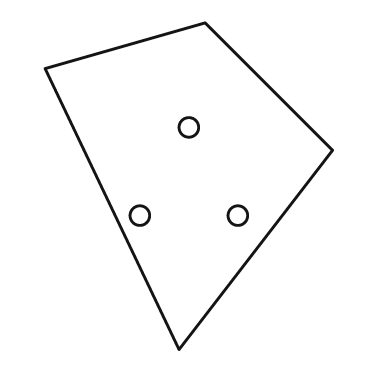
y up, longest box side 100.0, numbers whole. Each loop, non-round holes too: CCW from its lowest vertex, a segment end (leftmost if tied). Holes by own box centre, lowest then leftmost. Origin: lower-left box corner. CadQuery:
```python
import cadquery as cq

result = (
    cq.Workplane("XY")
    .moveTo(41.0, 0.0)
    .lineTo(88.0, 61.0)
    .lineTo(49.0, 100.0)
    .lineTo(0.0, 86.0)
    .close()
    .moveTo(29.0, 41.0)
    .circle(3.0)
    .moveTo(59.0, 41.0)
    .circle(3.0)
    .moveTo(44.0, 68.0)
    .circle(3.0)
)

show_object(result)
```